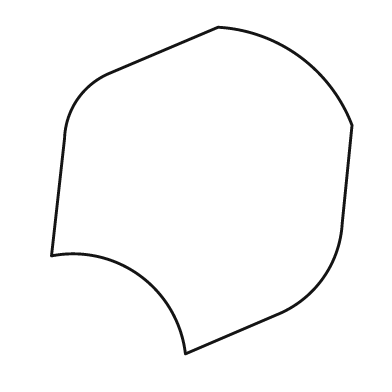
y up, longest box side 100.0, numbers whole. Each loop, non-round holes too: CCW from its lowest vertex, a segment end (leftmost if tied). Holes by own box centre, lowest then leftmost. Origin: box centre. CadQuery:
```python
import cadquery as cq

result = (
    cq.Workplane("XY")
    .moveTo(-5.0, -50.0)
    .lineTo(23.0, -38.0)
    .threePointArc((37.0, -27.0), (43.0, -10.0))
    .lineTo(46.0, 20.0)
    .threePointArc((30.0, 41.0), (5.0, 50.0))
    .lineTo(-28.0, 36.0)
    .threePointArc((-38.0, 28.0), (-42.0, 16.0))
    .lineTo(-46.0, -20.0)
    .threePointArc((-19.0, -26.0), (-5.0, -50.0))
    .close()
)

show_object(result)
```